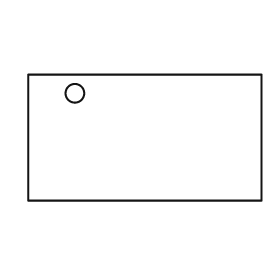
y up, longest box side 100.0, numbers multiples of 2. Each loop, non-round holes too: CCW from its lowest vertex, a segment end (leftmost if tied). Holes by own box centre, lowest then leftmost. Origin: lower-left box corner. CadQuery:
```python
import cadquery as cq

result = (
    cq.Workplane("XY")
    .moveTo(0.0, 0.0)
    .lineTo(100.0, 0.0)
    .lineTo(100.0, 54.0)
    .lineTo(0.0, 54.0)
    .close()
    .moveTo(20.0, 46.0)
    .circle(4.0)
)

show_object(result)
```